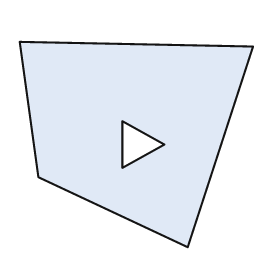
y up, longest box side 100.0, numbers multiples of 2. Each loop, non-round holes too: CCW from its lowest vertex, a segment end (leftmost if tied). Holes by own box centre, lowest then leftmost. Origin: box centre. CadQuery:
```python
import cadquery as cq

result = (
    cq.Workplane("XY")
    .moveTo(22.0, -44.0)
    .lineTo(50.0, 42.0)
    .lineTo(-50.0, 44.0)
    .lineTo(-42.0, -14.0)
    .close()
    .moveTo(-6.0, -10.0)
    .lineTo(12.0, 0.0)
    .lineTo(-6.0, 10.0)
    .close()
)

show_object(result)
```